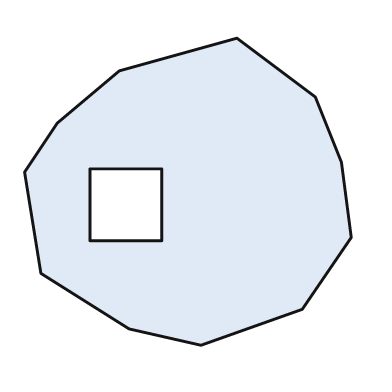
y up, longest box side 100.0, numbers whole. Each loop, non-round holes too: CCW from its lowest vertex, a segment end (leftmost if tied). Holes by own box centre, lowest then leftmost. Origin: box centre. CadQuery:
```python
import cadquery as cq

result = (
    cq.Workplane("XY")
    .moveTo(4.0, -47.0)
    .lineTo(35.0, -36.0)
    .lineTo(50.0, -14.0)
    .lineTo(47.0, 9.0)
    .lineTo(39.0, 29.0)
    .lineTo(15.0, 47.0)
    .lineTo(-21.0, 37.0)
    .lineTo(-40.0, 21.0)
    .lineTo(-50.0, 6.0)
    .lineTo(-45.0, -25.0)
    .lineTo(-18.0, -42.0)
    .close()
    .moveTo(-30.0, -15.0)
    .lineTo(-8.0, -15.0)
    .lineTo(-8.0, 7.0)
    .lineTo(-30.0, 7.0)
    .close()
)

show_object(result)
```